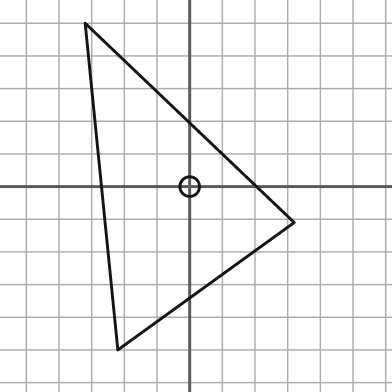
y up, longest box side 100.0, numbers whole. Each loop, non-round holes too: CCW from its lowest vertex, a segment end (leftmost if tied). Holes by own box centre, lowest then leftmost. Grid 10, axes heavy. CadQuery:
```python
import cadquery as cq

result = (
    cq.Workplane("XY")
    .moveTo(-22.0, -50.0)
    .lineTo(32.0, -11.0)
    .lineTo(-32.0, 50.0)
    .close()
    .moveTo(0.0, 0.0)
    .circle(3.0)
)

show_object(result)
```